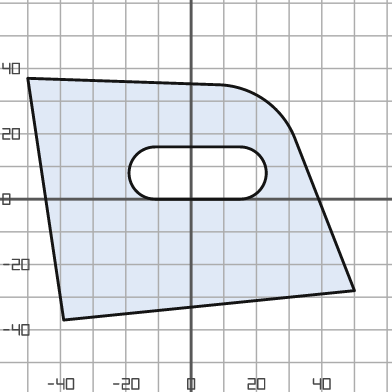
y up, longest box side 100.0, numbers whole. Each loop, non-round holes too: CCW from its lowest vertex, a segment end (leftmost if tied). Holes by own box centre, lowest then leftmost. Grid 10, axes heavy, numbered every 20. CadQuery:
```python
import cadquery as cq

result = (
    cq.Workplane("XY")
    .moveTo(-39.0, -37.0)
    .lineTo(50.0, -28.0)
    .lineTo(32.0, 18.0)
    .threePointArc((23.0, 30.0), (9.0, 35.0))
    .lineTo(-50.0, 37.0)
    .close()
    .moveTo(-11.0, 0.0)
    .lineTo(15.0, 0.0)
    .threePointArc((23.0, 8.0), (15.0, 16.0))
    .lineTo(-11.0, 16.0)
    .threePointArc((-19.0, 8.0), (-11.0, 0.0))
    .close()
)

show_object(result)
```